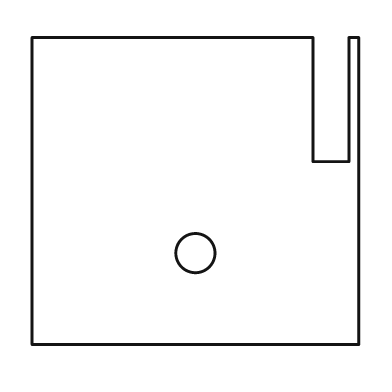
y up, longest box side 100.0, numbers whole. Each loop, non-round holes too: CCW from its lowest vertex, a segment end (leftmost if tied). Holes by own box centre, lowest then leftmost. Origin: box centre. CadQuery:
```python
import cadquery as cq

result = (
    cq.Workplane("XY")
    .moveTo(-50.0, -47.0)
    .lineTo(50.0, -47.0)
    .lineTo(50.0, 47.0)
    .lineTo(47.0, 47.0)
    .lineTo(47.0, 9.0)
    .lineTo(36.0, 9.0)
    .lineTo(36.0, 47.0)
    .lineTo(-50.0, 47.0)
    .close()
    .moveTo(0.0, -19.0)
    .circle(6.0)
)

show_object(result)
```